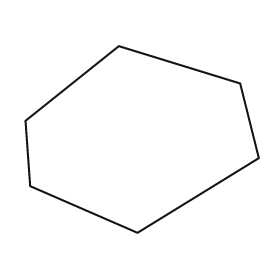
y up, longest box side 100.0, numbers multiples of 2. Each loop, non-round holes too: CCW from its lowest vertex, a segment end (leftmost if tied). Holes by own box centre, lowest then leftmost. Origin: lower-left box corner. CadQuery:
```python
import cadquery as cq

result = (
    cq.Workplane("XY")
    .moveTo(48.0, 0.0)
    .lineTo(100.0, 32.0)
    .lineTo(92.0, 64.0)
    .lineTo(40.0, 80.0)
    .lineTo(0.0, 48.0)
    .lineTo(2.0, 20.0)
    .close()
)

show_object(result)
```